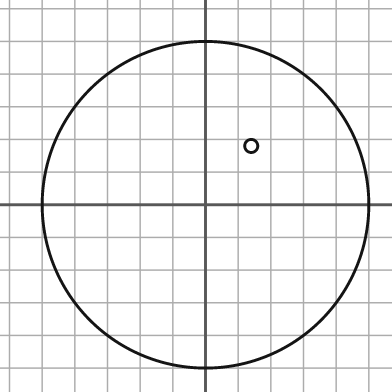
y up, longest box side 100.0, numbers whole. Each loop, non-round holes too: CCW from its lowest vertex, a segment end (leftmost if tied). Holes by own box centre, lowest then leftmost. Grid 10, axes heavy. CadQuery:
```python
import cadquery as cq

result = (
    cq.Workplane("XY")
    .moveTo(0.0, 0.0)
    .circle(50.0)
    .moveTo(14.0, 18.0)
    .circle(2.0)
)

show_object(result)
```